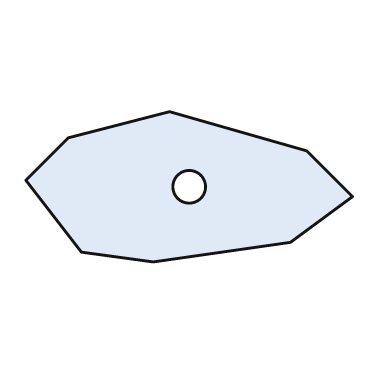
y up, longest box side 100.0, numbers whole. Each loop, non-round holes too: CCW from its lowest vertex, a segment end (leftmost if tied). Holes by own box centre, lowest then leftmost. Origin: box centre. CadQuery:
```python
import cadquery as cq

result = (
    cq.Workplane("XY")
    .moveTo(-11.0, -23.0)
    .lineTo(31.0, -17.0)
    .lineTo(50.0, -3.0)
    .lineTo(36.0, 11.0)
    .lineTo(-6.0, 23.0)
    .lineTo(-37.0, 15.0)
    .lineTo(-50.0, 2.0)
    .lineTo(-33.0, -20.0)
    .close()
    .moveTo(0.0, 0.0)
    .circle(5.0)
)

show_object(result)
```